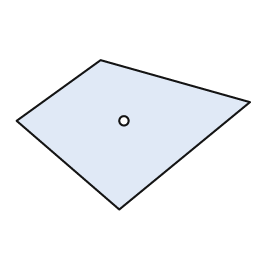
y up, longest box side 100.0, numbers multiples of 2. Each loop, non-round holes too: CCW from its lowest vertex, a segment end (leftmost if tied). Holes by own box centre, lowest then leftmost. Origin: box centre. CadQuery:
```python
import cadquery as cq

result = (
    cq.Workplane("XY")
    .moveTo(-6.0, -32.0)
    .lineTo(50.0, 14.0)
    .lineTo(-14.0, 32.0)
    .lineTo(-50.0, 6.0)
    .close()
    .moveTo(-4.0, 6.0)
    .circle(2.0)
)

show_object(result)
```